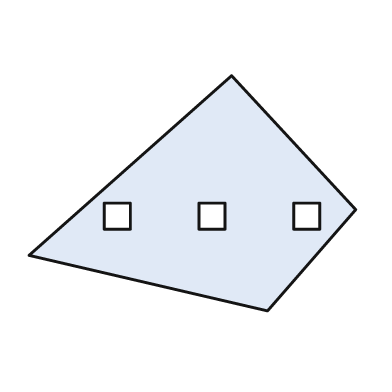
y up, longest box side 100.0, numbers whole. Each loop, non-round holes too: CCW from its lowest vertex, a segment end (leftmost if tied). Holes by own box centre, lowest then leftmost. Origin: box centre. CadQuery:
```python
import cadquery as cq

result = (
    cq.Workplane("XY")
    .moveTo(23.0, -36.0)
    .lineTo(50.0, -5.0)
    .lineTo(12.0, 36.0)
    .lineTo(-50.0, -19.0)
    .close()
    .moveTo(-27.0, -11.0)
    .lineTo(-19.0, -11.0)
    .lineTo(-19.0, -3.0)
    .lineTo(-27.0, -3.0)
    .close()
    .moveTo(2.0, -11.0)
    .lineTo(10.0, -11.0)
    .lineTo(10.0, -3.0)
    .lineTo(2.0, -3.0)
    .close()
    .moveTo(31.0, -11.0)
    .lineTo(39.0, -11.0)
    .lineTo(39.0, -3.0)
    .lineTo(31.0, -3.0)
    .close()
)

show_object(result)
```